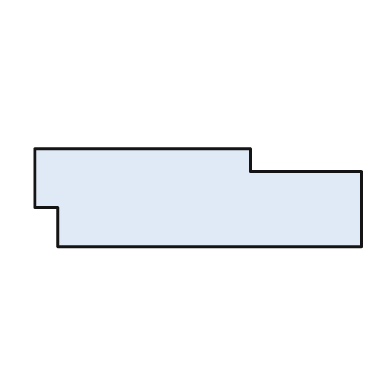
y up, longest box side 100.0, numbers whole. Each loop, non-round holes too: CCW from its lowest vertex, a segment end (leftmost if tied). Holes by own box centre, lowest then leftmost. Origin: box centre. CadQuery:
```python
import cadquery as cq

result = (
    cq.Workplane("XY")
    .moveTo(-43.0, -15.0)
    .lineTo(50.0, -15.0)
    .lineTo(50.0, 8.0)
    .lineTo(16.0, 8.0)
    .lineTo(16.0, 15.0)
    .lineTo(-50.0, 15.0)
    .lineTo(-50.0, -3.0)
    .lineTo(-43.0, -3.0)
    .close()
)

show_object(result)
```